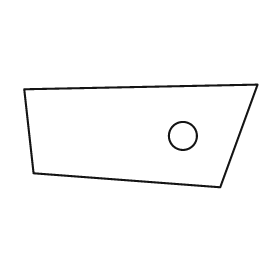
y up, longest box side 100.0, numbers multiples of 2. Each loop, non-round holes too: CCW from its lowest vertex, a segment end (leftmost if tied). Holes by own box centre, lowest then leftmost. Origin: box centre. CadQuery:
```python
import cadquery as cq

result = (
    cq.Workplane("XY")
    .moveTo(34.0, -22.0)
    .lineTo(50.0, 22.0)
    .lineTo(-50.0, 20.0)
    .lineTo(-46.0, -16.0)
    .close()
    .moveTo(18.0, 0.0)
    .circle(6.0)
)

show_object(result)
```